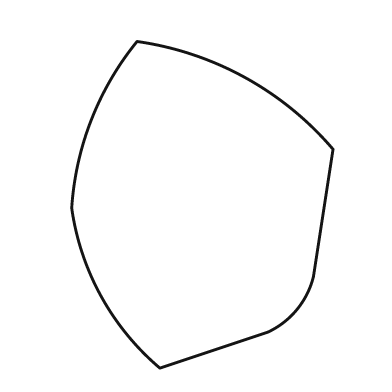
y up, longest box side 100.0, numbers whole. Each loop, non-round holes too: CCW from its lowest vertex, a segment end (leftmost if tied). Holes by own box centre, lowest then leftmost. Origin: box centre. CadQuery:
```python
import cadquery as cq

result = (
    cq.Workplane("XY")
    .moveTo(-13.0, -50.0)
    .lineTo(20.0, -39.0)
    .threePointArc((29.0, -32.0), (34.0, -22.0))
    .lineTo(40.0, 17.0)
    .threePointArc((13.0, 39.0), (-20.0, 50.0))
    .threePointArc((-34.0, 26.0), (-40.0, -1.0))
    .threePointArc((-31.0, -28.0), (-13.0, -50.0))
    .close()
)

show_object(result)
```